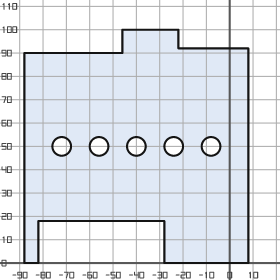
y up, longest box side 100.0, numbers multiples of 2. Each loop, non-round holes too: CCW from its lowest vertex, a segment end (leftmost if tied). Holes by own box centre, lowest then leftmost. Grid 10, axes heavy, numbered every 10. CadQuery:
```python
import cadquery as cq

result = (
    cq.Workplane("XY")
    .moveTo(-88.0, 0.0)
    .lineTo(-82.0, 0.0)
    .lineTo(-82.0, 18.0)
    .lineTo(-28.0, 18.0)
    .lineTo(-28.0, 0.0)
    .lineTo(8.0, 0.0)
    .lineTo(8.0, 92.0)
    .lineTo(-22.0, 92.0)
    .lineTo(-22.0, 100.0)
    .lineTo(-46.0, 100.0)
    .lineTo(-46.0, 90.0)
    .lineTo(-88.0, 90.0)
    .close()
    .moveTo(-72.0, 50.0)
    .circle(4.0)
    .moveTo(-56.0, 50.0)
    .circle(4.0)
    .moveTo(-40.0, 50.0)
    .circle(4.0)
    .moveTo(-24.0, 50.0)
    .circle(4.0)
    .moveTo(-8.0, 50.0)
    .circle(4.0)
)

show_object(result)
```